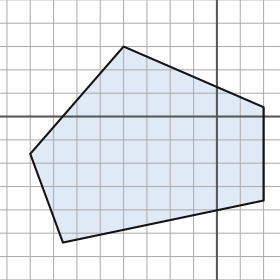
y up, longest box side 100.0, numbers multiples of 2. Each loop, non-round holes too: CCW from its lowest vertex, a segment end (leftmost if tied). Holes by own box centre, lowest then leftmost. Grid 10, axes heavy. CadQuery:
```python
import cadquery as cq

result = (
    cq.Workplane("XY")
    .moveTo(-66.0, -54.0)
    .lineTo(20.0, -36.0)
    .lineTo(20.0, 4.0)
    .lineTo(-40.0, 30.0)
    .lineTo(-80.0, -16.0)
    .close()
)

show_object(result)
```